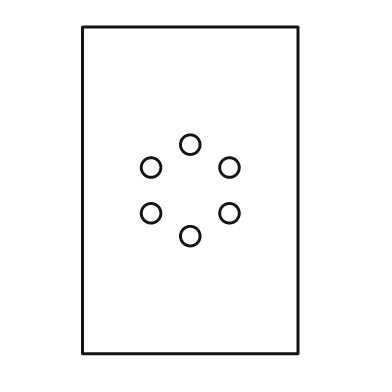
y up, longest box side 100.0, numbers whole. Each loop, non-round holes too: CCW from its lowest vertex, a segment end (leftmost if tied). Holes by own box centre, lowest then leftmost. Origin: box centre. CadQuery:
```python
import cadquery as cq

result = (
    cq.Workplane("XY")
    .moveTo(-33.0, -50.0)
    .lineTo(33.0, -50.0)
    .lineTo(33.0, 50.0)
    .lineTo(-33.0, 50.0)
    .close()
    .moveTo(0.0, -14.0)
    .circle(3.0)
    .moveTo(-12.0, -7.0)
    .circle(3.0)
    .moveTo(12.0, -7.0)
    .circle(3.0)
    .moveTo(-12.0, 7.0)
    .circle(3.0)
    .moveTo(12.0, 7.0)
    .circle(3.0)
    .moveTo(0.0, 14.0)
    .circle(3.0)
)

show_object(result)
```